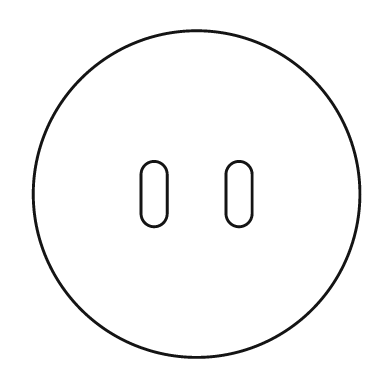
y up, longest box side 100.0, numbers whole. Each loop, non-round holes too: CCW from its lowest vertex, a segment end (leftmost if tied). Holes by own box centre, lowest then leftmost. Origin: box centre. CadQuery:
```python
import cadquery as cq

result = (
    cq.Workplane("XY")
    .moveTo(0.0, 0.0)
    .circle(50.0)
    .moveTo(-17.0, -6.0)
    .threePointArc((-13.0, -10.0), (-9.0, -6.0))
    .lineTo(-9.0, 6.0)
    .threePointArc((-13.0, 10.0), (-17.0, 6.0))
    .close()
    .moveTo(9.0, -6.0)
    .threePointArc((13.0, -10.0), (17.0, -6.0))
    .lineTo(17.0, 6.0)
    .threePointArc((13.0, 10.0), (9.0, 6.0))
    .close()
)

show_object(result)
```